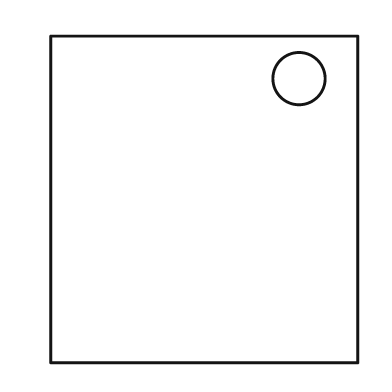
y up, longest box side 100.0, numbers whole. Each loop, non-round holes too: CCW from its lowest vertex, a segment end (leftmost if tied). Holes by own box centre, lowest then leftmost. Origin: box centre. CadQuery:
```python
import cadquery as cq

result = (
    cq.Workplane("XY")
    .moveTo(-47.0, -50.0)
    .lineTo(47.0, -50.0)
    .lineTo(47.0, 50.0)
    .lineTo(-47.0, 50.0)
    .close()
    .moveTo(29.0, 37.0)
    .circle(8.0)
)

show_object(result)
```